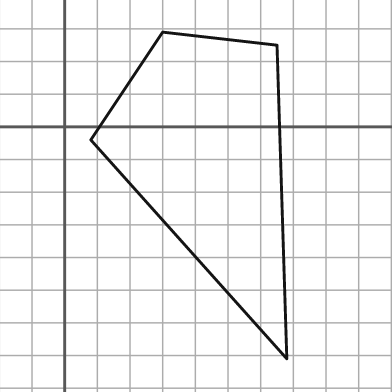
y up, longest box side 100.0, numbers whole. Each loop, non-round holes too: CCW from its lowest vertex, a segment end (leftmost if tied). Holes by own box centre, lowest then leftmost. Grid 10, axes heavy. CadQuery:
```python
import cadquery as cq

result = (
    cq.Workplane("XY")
    .moveTo(68.0, -71.0)
    .lineTo(65.0, 25.0)
    .lineTo(30.0, 29.0)
    .lineTo(8.0, -4.0)
    .close()
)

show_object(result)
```